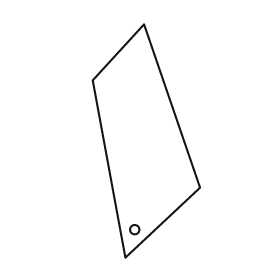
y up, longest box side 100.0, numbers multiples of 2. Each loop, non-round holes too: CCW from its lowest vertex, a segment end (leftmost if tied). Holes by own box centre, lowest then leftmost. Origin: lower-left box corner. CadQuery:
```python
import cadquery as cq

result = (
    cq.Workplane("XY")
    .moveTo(14.0, 0.0)
    .lineTo(46.0, 30.0)
    .lineTo(22.0, 100.0)
    .lineTo(0.0, 76.0)
    .close()
    .moveTo(18.0, 12.0)
    .circle(2.0)
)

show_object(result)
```